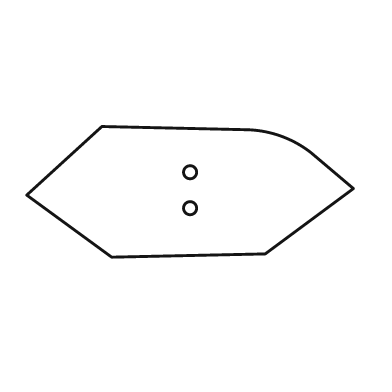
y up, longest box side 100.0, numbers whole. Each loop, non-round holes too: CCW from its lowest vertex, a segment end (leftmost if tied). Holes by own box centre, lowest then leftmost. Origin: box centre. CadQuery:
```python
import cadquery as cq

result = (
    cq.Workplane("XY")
    .moveTo(-24.0, -20.0)
    .lineTo(23.0, -19.0)
    .lineTo(50.0, 1.0)
    .lineTo(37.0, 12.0)
    .threePointArc((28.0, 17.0), (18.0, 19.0))
    .lineTo(-27.0, 20.0)
    .lineTo(-50.0, -1.0)
    .close()
    .moveTo(0.0, -5.0)
    .circle(2.0)
    .moveTo(0.0, 6.0)
    .circle(2.0)
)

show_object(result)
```